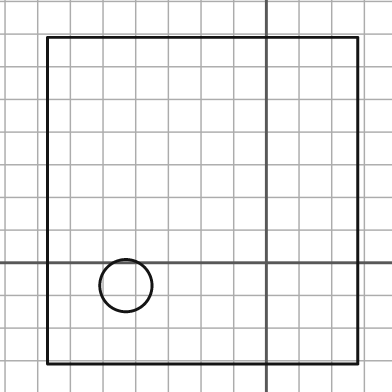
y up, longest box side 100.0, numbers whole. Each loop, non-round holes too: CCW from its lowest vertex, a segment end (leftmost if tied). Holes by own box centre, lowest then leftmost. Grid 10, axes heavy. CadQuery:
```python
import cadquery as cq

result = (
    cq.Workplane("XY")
    .moveTo(-67.0, -31.0)
    .lineTo(28.0, -31.0)
    .lineTo(28.0, 69.0)
    .lineTo(-67.0, 69.0)
    .close()
    .moveTo(-43.0, -7.0)
    .circle(8.0)
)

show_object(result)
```